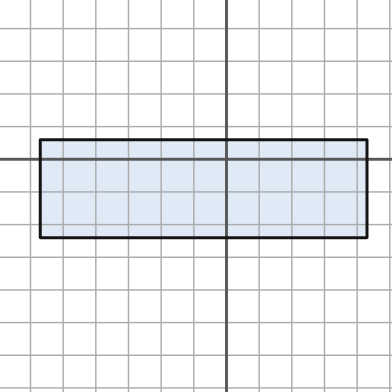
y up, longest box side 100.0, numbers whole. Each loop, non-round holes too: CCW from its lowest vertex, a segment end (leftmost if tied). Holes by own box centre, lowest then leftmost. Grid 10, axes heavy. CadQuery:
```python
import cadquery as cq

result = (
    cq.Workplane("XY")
    .moveTo(-57.0, -24.0)
    .lineTo(43.0, -24.0)
    .lineTo(43.0, 6.0)
    .lineTo(-57.0, 6.0)
    .close()
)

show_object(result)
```